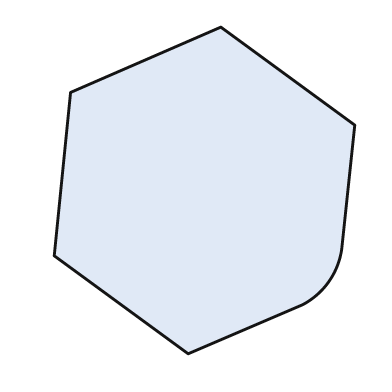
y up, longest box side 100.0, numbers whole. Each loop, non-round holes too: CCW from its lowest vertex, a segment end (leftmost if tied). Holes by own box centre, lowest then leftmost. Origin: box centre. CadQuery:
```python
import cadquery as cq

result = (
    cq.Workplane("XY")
    .moveTo(-5.0, -50.0)
    .lineTo(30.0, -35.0)
    .threePointArc((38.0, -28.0), (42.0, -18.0))
    .lineTo(46.0, 20.0)
    .lineTo(5.0, 50.0)
    .lineTo(-41.0, 30.0)
    .lineTo(-46.0, -20.0)
    .close()
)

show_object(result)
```